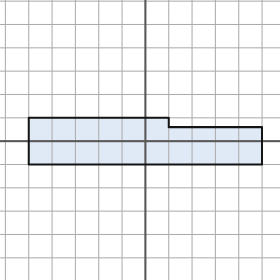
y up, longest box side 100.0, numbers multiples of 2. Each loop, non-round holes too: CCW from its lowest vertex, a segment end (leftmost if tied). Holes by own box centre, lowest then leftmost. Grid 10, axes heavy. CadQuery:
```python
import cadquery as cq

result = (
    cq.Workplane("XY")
    .moveTo(-50.0, -10.0)
    .lineTo(50.0, -10.0)
    .lineTo(50.0, 6.0)
    .lineTo(10.0, 6.0)
    .lineTo(10.0, 10.0)
    .lineTo(-50.0, 10.0)
    .close()
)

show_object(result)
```